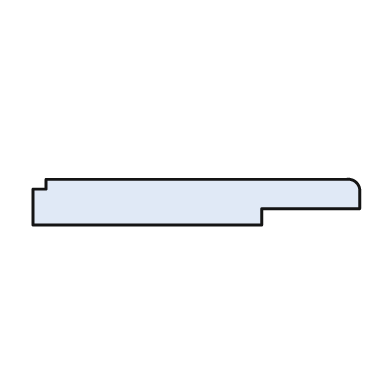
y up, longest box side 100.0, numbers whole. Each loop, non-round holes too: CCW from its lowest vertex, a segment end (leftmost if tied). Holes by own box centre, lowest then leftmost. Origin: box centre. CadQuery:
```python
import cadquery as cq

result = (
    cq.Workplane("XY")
    .moveTo(-50.0, -7.0)
    .lineTo(20.0, -7.0)
    .lineTo(20.0, -2.0)
    .lineTo(50.0, -2.0)
    .lineTo(50.0, 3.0)
    .threePointArc((49.0, 6.0), (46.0, 7.0))
    .lineTo(-46.0, 7.0)
    .lineTo(-46.0, 4.0)
    .lineTo(-50.0, 4.0)
    .close()
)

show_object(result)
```